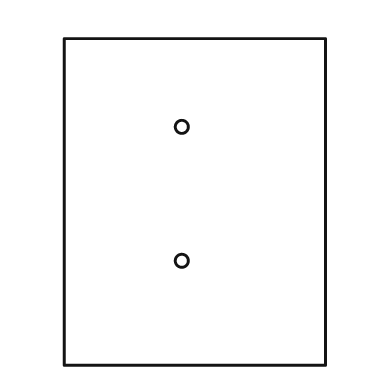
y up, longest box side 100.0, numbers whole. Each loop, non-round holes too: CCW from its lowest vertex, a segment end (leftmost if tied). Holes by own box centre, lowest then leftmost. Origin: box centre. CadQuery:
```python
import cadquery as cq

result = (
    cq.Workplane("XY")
    .moveTo(-40.0, -50.0)
    .lineTo(40.0, -50.0)
    .lineTo(40.0, 50.0)
    .lineTo(-40.0, 50.0)
    .close()
    .moveTo(-4.0, -18.0)
    .circle(2.0)
    .moveTo(-4.0, 23.0)
    .circle(2.0)
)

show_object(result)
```